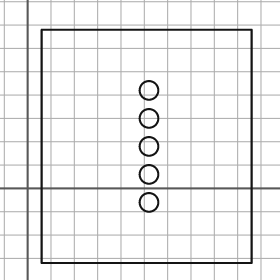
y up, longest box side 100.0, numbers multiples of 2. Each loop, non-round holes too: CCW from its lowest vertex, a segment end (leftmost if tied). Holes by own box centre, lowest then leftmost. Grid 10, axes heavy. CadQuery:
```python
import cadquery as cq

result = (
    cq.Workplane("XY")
    .moveTo(6.0, -32.0)
    .lineTo(96.0, -32.0)
    .lineTo(96.0, 68.0)
    .lineTo(6.0, 68.0)
    .close()
    .moveTo(52.0, -6.0)
    .circle(4.0)
    .moveTo(52.0, 6.0)
    .circle(4.0)
    .moveTo(52.0, 18.0)
    .circle(4.0)
    .moveTo(52.0, 30.0)
    .circle(4.0)
    .moveTo(52.0, 42.0)
    .circle(4.0)
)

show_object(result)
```